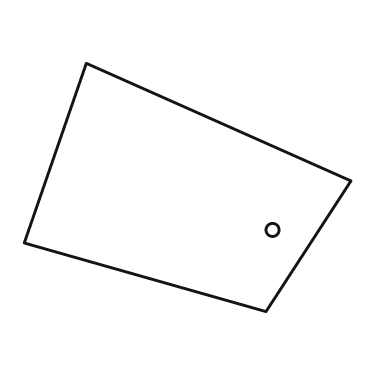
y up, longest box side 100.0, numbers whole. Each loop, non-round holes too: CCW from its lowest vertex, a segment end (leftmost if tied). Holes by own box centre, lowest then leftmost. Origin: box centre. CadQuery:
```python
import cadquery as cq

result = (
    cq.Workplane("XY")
    .moveTo(24.0, -38.0)
    .lineTo(50.0, 2.0)
    .lineTo(-31.0, 38.0)
    .lineTo(-50.0, -17.0)
    .close()
    .moveTo(26.0, -13.0)
    .circle(2.0)
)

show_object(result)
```